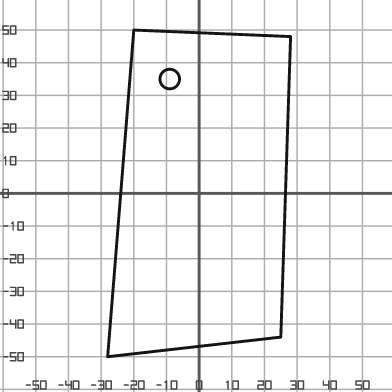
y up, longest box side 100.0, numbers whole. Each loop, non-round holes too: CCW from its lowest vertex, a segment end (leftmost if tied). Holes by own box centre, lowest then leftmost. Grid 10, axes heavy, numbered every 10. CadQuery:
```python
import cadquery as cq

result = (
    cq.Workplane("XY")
    .moveTo(-28.0, -50.0)
    .lineTo(25.0, -44.0)
    .lineTo(28.0, 48.0)
    .lineTo(-20.0, 50.0)
    .close()
    .moveTo(-9.0, 35.0)
    .circle(3.0)
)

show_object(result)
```